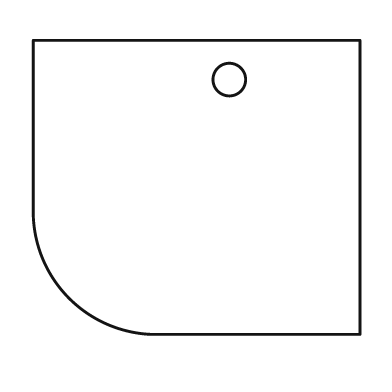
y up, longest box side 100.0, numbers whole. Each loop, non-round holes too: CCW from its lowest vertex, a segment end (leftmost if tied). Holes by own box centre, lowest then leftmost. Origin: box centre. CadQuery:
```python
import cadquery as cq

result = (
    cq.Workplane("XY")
    .moveTo(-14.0, -45.0)
    .lineTo(50.0, -45.0)
    .lineTo(50.0, 45.0)
    .lineTo(-50.0, 45.0)
    .lineTo(-50.0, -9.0)
    .threePointArc((-39.0, -34.0), (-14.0, -45.0))
    .close()
    .moveTo(10.0, 33.0)
    .circle(5.0)
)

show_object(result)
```